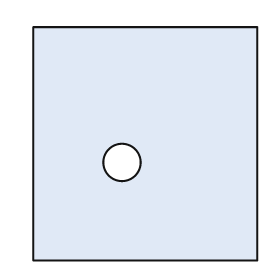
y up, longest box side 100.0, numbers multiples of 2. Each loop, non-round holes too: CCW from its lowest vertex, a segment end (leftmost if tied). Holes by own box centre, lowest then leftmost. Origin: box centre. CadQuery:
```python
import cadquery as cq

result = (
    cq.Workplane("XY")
    .moveTo(-48.0, -50.0)
    .lineTo(48.0, -50.0)
    .lineTo(48.0, 50.0)
    .lineTo(-48.0, 50.0)
    .close()
    .moveTo(-10.0, -8.0)
    .circle(8.0)
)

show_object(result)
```